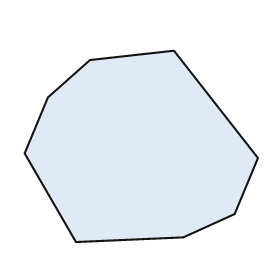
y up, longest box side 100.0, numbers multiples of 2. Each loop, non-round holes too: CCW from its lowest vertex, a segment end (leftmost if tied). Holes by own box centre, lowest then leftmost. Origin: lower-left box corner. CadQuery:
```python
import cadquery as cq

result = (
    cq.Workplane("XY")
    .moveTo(22.0, 0.0)
    .lineTo(68.0, 2.0)
    .lineTo(90.0, 12.0)
    .lineTo(100.0, 36.0)
    .lineTo(64.0, 82.0)
    .lineTo(28.0, 78.0)
    .lineTo(10.0, 62.0)
    .lineTo(0.0, 38.0)
    .close()
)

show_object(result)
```